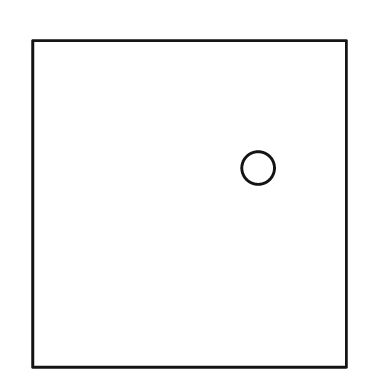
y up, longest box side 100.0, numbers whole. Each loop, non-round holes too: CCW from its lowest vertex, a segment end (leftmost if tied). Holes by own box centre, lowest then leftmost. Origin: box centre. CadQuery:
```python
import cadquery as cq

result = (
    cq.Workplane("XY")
    .moveTo(-48.0, -50.0)
    .lineTo(48.0, -50.0)
    .lineTo(48.0, 50.0)
    .lineTo(-48.0, 50.0)
    .close()
    .moveTo(21.0, 11.0)
    .circle(5.0)
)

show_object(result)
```